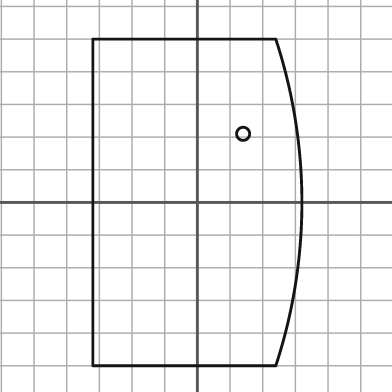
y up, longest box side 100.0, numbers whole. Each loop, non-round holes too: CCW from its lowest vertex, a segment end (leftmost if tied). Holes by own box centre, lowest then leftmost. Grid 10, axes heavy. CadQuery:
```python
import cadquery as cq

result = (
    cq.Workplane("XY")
    .moveTo(-32.0, -50.0)
    .lineTo(24.0, -50.0)
    .threePointArc((32.0, 0.0), (24.0, 50.0))
    .lineTo(-32.0, 50.0)
    .close()
    .moveTo(14.0, 21.0)
    .circle(2.0)
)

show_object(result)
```